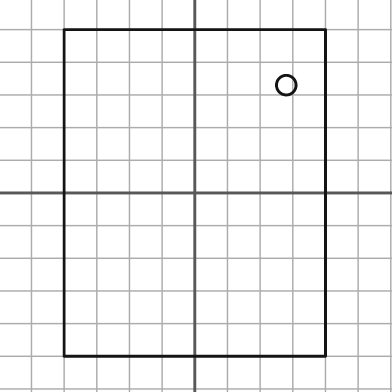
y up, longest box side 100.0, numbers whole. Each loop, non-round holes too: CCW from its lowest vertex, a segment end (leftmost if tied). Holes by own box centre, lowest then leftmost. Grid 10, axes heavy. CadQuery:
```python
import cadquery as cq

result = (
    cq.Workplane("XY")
    .moveTo(-40.0, -50.0)
    .lineTo(40.0, -50.0)
    .lineTo(40.0, 50.0)
    .lineTo(-40.0, 50.0)
    .close()
    .moveTo(28.0, 33.0)
    .circle(3.0)
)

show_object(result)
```